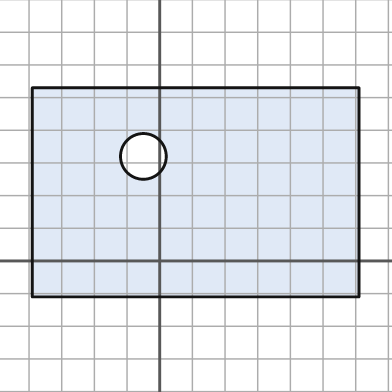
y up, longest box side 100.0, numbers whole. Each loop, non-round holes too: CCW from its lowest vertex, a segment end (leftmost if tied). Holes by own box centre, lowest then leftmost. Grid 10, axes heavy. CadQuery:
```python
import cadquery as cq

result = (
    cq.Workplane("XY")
    .moveTo(-39.0, -11.0)
    .lineTo(61.0, -11.0)
    .lineTo(61.0, 53.0)
    .lineTo(-39.0, 53.0)
    .close()
    .moveTo(-5.0, 32.0)
    .circle(7.0)
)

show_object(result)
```